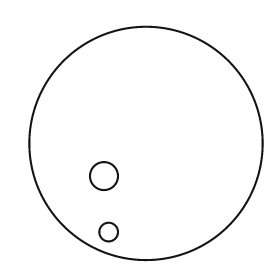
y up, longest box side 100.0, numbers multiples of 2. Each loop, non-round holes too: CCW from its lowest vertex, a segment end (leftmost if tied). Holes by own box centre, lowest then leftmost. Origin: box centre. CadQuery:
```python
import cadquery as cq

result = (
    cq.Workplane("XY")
    .moveTo(0.0, 0.0)
    .circle(50.0)
    .moveTo(-16.0, -38.0)
    .circle(4.0)
    .moveTo(-18.0, -14.0)
    .circle(6.0)
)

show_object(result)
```